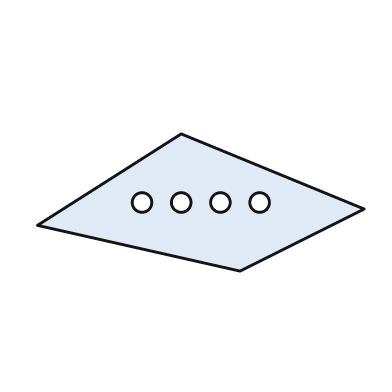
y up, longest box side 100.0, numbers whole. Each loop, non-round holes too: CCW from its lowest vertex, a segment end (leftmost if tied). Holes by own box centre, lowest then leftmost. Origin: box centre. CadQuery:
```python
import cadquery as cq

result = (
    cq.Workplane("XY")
    .moveTo(12.0, -21.0)
    .lineTo(50.0, -2.0)
    .lineTo(-6.0, 21.0)
    .lineTo(-50.0, -7.0)
    .close()
    .moveTo(-18.0, 0.0)
    .circle(3.0)
    .moveTo(-6.0, 0.0)
    .circle(3.0)
    .moveTo(6.0, 0.0)
    .circle(3.0)
    .moveTo(18.0, 0.0)
    .circle(3.0)
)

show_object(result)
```